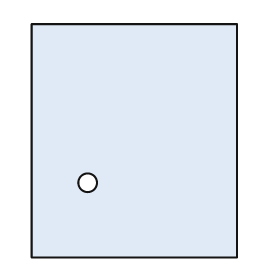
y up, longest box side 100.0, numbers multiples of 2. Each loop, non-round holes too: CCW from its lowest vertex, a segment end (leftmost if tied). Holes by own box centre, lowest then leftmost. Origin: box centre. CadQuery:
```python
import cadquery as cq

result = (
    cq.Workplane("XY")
    .moveTo(-44.0, -50.0)
    .lineTo(44.0, -50.0)
    .lineTo(44.0, 50.0)
    .lineTo(-44.0, 50.0)
    .close()
    .moveTo(-20.0, -18.0)
    .circle(4.0)
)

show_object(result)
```